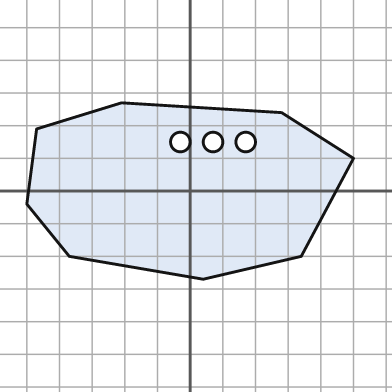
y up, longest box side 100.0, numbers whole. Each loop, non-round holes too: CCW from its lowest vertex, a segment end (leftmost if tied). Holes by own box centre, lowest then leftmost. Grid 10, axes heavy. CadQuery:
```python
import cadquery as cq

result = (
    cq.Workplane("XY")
    .moveTo(4.0, -27.0)
    .lineTo(34.0, -20.0)
    .lineTo(50.0, 10.0)
    .lineTo(28.0, 24.0)
    .lineTo(-21.0, 27.0)
    .lineTo(-47.0, 19.0)
    .lineTo(-50.0, -4.0)
    .lineTo(-37.0, -20.0)
    .close()
    .moveTo(-3.0, 15.0)
    .circle(3.0)
    .moveTo(7.0, 15.0)
    .circle(3.0)
    .moveTo(17.0, 15.0)
    .circle(3.0)
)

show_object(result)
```